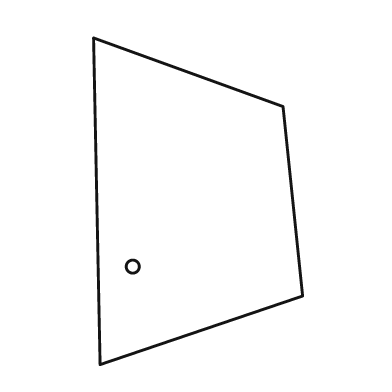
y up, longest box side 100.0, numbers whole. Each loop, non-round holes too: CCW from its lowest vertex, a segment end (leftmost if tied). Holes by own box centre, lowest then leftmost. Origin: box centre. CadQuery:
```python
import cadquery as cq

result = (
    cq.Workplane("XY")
    .moveTo(-30.0, -50.0)
    .lineTo(32.0, -29.0)
    .lineTo(26.0, 29.0)
    .lineTo(-32.0, 50.0)
    .close()
    .moveTo(-20.0, -20.0)
    .circle(2.0)
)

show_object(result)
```